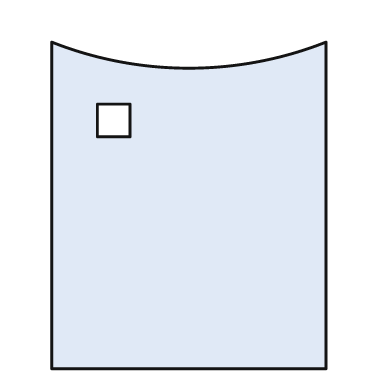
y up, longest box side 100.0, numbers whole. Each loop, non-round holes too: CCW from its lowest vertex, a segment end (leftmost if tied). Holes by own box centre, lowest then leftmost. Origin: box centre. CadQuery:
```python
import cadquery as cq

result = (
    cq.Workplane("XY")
    .moveTo(-42.0, -50.0)
    .lineTo(42.0, -50.0)
    .lineTo(42.0, 50.0)
    .threePointArc((0.0, 42.0), (-42.0, 50.0))
    .close()
    .moveTo(-28.0, 21.0)
    .lineTo(-18.0, 21.0)
    .lineTo(-18.0, 31.0)
    .lineTo(-28.0, 31.0)
    .close()
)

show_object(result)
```